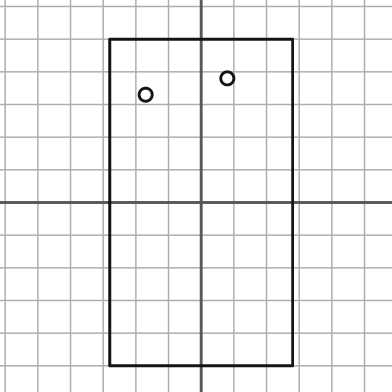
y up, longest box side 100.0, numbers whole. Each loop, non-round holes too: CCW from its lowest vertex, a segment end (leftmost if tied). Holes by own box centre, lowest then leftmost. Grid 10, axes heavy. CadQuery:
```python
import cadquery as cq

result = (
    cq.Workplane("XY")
    .moveTo(-28.0, -50.0)
    .lineTo(28.0, -50.0)
    .lineTo(28.0, 50.0)
    .lineTo(-28.0, 50.0)
    .close()
    .moveTo(-17.0, 33.0)
    .circle(2.0)
    .moveTo(8.0, 38.0)
    .circle(2.0)
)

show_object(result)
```